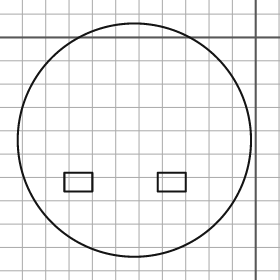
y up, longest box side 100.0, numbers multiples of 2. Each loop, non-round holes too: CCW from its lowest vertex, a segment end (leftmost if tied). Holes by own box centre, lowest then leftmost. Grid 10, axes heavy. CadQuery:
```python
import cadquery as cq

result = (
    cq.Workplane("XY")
    .moveTo(-52.0, -44.0)
    .circle(50.0)
    .moveTo(-82.0, -66.0)
    .lineTo(-70.0, -66.0)
    .lineTo(-70.0, -58.0)
    .lineTo(-82.0, -58.0)
    .close()
    .moveTo(-42.0, -66.0)
    .lineTo(-30.0, -66.0)
    .lineTo(-30.0, -58.0)
    .lineTo(-42.0, -58.0)
    .close()
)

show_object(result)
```